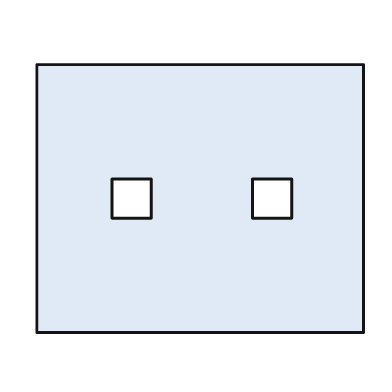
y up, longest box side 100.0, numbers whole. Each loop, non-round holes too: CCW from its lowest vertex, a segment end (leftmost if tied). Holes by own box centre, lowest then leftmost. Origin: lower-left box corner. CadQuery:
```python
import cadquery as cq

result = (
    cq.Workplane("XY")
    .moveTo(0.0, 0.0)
    .lineTo(100.0, 0.0)
    .lineTo(100.0, 82.0)
    .lineTo(0.0, 82.0)
    .close()
    .moveTo(23.0, 35.0)
    .lineTo(35.0, 35.0)
    .lineTo(35.0, 47.0)
    .lineTo(23.0, 47.0)
    .close()
    .moveTo(66.0, 35.0)
    .lineTo(78.0, 35.0)
    .lineTo(78.0, 47.0)
    .lineTo(66.0, 47.0)
    .close()
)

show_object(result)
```